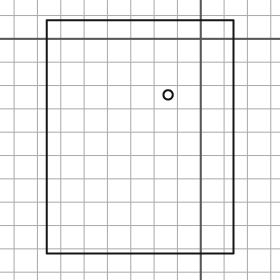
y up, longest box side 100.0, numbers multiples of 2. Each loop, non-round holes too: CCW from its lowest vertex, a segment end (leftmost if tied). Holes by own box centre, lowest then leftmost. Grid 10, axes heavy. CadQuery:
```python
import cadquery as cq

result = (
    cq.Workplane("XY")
    .moveTo(-66.0, -92.0)
    .lineTo(14.0, -92.0)
    .lineTo(14.0, 8.0)
    .lineTo(-66.0, 8.0)
    .close()
    .moveTo(-14.0, -24.0)
    .circle(2.0)
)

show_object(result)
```